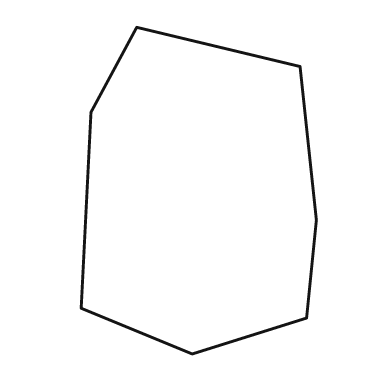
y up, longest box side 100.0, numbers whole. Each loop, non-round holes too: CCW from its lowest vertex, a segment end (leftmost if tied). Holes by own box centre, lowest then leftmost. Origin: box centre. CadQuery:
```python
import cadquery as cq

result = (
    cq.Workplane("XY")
    .moveTo(-2.0, -50.0)
    .lineTo(33.0, -39.0)
    .lineTo(36.0, -9.0)
    .lineTo(31.0, 38.0)
    .lineTo(-19.0, 50.0)
    .lineTo(-33.0, 24.0)
    .lineTo(-36.0, -36.0)
    .close()
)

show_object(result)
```